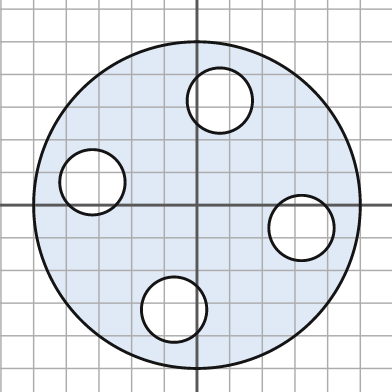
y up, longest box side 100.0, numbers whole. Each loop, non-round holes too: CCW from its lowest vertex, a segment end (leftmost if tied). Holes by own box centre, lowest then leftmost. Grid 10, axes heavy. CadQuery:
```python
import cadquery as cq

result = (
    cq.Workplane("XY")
    .moveTo(0.0, 0.0)
    .circle(50.0)
    .moveTo(-7.0, -32.0)
    .circle(10.0)
    .moveTo(32.0, -7.0)
    .circle(10.0)
    .moveTo(-32.0, 7.0)
    .circle(10.0)
    .moveTo(7.0, 32.0)
    .circle(10.0)
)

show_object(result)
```